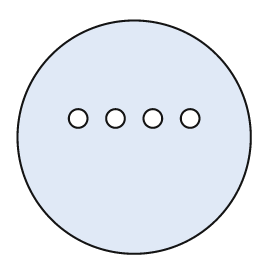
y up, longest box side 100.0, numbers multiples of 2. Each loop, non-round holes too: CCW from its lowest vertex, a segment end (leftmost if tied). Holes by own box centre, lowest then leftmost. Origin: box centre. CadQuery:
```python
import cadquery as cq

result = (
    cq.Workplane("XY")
    .moveTo(0.0, 0.0)
    .circle(50.0)
    .moveTo(-24.0, 8.0)
    .circle(4.0)
    .moveTo(-8.0, 8.0)
    .circle(4.0)
    .moveTo(8.0, 8.0)
    .circle(4.0)
    .moveTo(24.0, 8.0)
    .circle(4.0)
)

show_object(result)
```